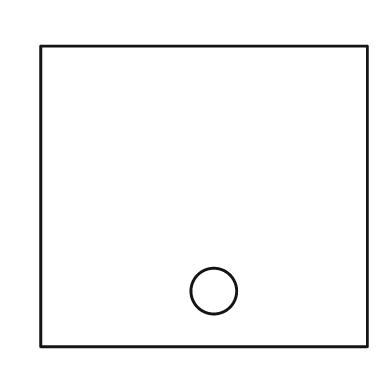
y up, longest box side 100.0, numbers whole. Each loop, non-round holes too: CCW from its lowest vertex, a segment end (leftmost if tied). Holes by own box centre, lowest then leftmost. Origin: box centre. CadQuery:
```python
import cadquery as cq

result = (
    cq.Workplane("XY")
    .moveTo(-50.0, -46.0)
    .lineTo(50.0, -46.0)
    .lineTo(50.0, 46.0)
    .lineTo(-50.0, 46.0)
    .close()
    .moveTo(3.0, -29.0)
    .circle(7.0)
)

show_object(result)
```